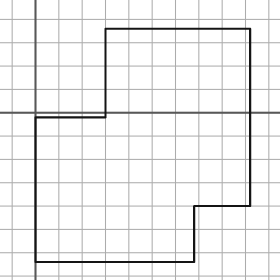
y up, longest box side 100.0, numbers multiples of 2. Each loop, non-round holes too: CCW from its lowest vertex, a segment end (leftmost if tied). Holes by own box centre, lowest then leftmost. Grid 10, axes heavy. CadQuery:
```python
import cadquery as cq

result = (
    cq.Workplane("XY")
    .moveTo(0.0, -64.0)
    .lineTo(68.0, -64.0)
    .lineTo(68.0, -40.0)
    .lineTo(92.0, -40.0)
    .lineTo(92.0, 36.0)
    .lineTo(30.0, 36.0)
    .lineTo(30.0, -2.0)
    .lineTo(0.0, -2.0)
    .close()
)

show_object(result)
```